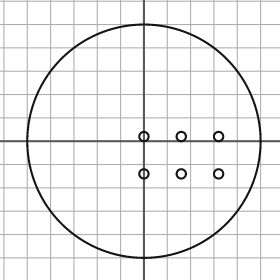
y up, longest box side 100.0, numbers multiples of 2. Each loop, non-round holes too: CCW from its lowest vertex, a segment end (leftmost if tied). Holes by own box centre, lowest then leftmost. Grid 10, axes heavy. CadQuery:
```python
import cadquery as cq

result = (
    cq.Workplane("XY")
    .moveTo(0.0, 0.0)
    .circle(50.0)
    .moveTo(0.0, -14.0)
    .circle(2.0)
    .moveTo(16.0, -14.0)
    .circle(2.0)
    .moveTo(32.0, -14.0)
    .circle(2.0)
    .moveTo(0.0, 2.0)
    .circle(2.0)
    .moveTo(16.0, 2.0)
    .circle(2.0)
    .moveTo(32.0, 2.0)
    .circle(2.0)
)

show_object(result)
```